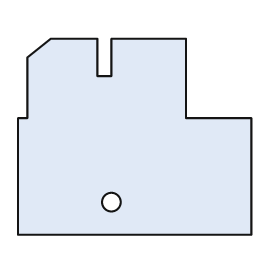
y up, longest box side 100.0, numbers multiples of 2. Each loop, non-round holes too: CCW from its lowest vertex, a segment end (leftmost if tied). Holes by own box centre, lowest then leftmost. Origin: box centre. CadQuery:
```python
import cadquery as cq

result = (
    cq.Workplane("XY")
    .moveTo(-50.0, -42.0)
    .lineTo(50.0, -42.0)
    .lineTo(50.0, 8.0)
    .lineTo(22.0, 8.0)
    .lineTo(22.0, 42.0)
    .lineTo(-10.0, 42.0)
    .lineTo(-10.0, 26.0)
    .lineTo(-16.0, 26.0)
    .lineTo(-16.0, 42.0)
    .lineTo(-36.0, 42.0)
    .lineTo(-46.0, 34.0)
    .lineTo(-46.0, 8.0)
    .lineTo(-50.0, 8.0)
    .close()
    .moveTo(-10.0, -28.0)
    .circle(4.0)
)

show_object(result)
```